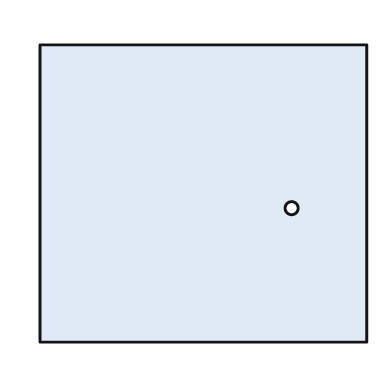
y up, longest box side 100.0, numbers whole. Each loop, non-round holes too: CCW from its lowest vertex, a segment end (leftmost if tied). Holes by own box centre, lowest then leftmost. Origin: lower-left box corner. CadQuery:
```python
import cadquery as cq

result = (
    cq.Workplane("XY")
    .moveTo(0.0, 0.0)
    .lineTo(100.0, 0.0)
    .lineTo(100.0, 91.0)
    .lineTo(0.0, 91.0)
    .close()
    .moveTo(77.0, 41.0)
    .circle(2.0)
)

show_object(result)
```